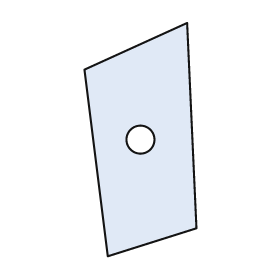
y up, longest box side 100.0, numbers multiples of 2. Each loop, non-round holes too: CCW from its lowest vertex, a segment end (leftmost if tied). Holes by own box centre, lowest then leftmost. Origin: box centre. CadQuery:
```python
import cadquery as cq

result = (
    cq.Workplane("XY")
    .moveTo(-14.0, -50.0)
    .lineTo(24.0, -38.0)
    .lineTo(20.0, 50.0)
    .lineTo(-24.0, 30.0)
    .close()
    .moveTo(0.0, 0.0)
    .circle(6.0)
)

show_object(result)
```